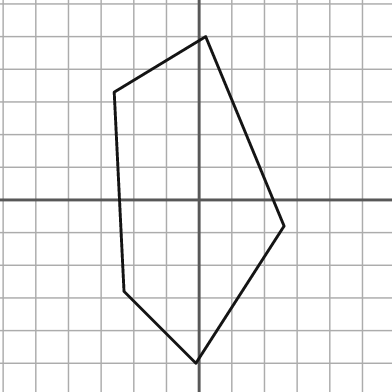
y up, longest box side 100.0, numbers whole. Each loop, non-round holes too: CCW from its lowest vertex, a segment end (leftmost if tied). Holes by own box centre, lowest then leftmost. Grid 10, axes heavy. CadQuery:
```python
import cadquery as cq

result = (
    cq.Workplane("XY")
    .moveTo(-1.0, -50.0)
    .lineTo(26.0, -8.0)
    .lineTo(2.0, 50.0)
    .lineTo(-26.0, 33.0)
    .lineTo(-23.0, -28.0)
    .close()
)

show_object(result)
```